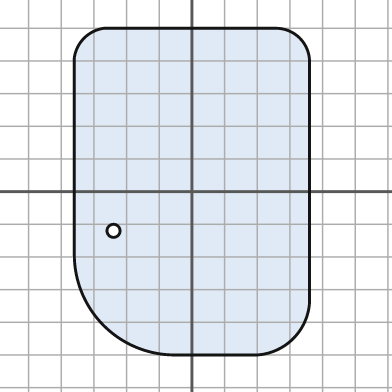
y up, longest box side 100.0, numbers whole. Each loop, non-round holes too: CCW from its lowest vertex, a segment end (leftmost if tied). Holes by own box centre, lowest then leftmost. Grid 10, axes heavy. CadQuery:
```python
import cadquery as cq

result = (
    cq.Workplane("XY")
    .moveTo(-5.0, -50.0)
    .lineTo(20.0, -50.0)
    .threePointArc((31.0, -45.0), (36.0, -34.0))
    .lineTo(36.0, 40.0)
    .threePointArc((33.0, 47.0), (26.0, 50.0))
    .lineTo(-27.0, 50.0)
    .threePointArc((-33.0, 47.0), (-36.0, 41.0))
    .lineTo(-36.0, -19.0)
    .threePointArc((-27.0, -41.0), (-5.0, -50.0))
    .close()
    .moveTo(-24.0, -12.0)
    .circle(2.0)
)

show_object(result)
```